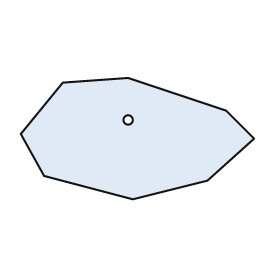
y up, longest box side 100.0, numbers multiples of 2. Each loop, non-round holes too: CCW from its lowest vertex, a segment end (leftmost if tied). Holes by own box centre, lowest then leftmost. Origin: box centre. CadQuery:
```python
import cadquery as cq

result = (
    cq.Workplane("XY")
    .moveTo(-2.0, -26.0)
    .lineTo(30.0, -18.0)
    .lineTo(50.0, 0.0)
    .lineTo(38.0, 12.0)
    .lineTo(-4.0, 26.0)
    .lineTo(-32.0, 24.0)
    .lineTo(-50.0, 2.0)
    .lineTo(-40.0, -16.0)
    .close()
    .moveTo(-4.0, 8.0)
    .circle(2.0)
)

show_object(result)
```